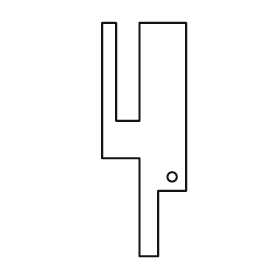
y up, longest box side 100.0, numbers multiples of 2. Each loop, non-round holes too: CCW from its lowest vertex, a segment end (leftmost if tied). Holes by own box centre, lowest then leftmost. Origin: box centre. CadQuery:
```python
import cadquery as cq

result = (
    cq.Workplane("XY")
    .moveTo(-2.0, -50.0)
    .lineTo(6.0, -50.0)
    .lineTo(6.0, -22.0)
    .lineTo(18.0, -22.0)
    .lineTo(18.0, 50.0)
    .lineTo(-2.0, 50.0)
    .lineTo(-2.0, 8.0)
    .lineTo(-12.0, 8.0)
    .lineTo(-12.0, 50.0)
    .lineTo(-18.0, 50.0)
    .lineTo(-18.0, -8.0)
    .lineTo(-2.0, -8.0)
    .close()
    .moveTo(12.0, -16.0)
    .circle(2.0)
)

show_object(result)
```